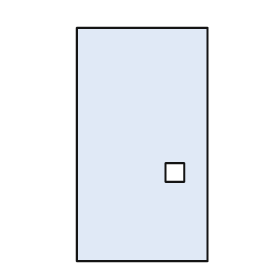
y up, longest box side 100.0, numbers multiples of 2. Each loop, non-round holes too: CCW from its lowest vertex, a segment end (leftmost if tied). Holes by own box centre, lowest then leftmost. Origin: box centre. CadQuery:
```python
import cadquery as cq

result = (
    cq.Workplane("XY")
    .moveTo(-28.0, -50.0)
    .lineTo(28.0, -50.0)
    .lineTo(28.0, 50.0)
    .lineTo(-28.0, 50.0)
    .close()
    .moveTo(10.0, -16.0)
    .lineTo(18.0, -16.0)
    .lineTo(18.0, -8.0)
    .lineTo(10.0, -8.0)
    .close()
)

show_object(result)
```